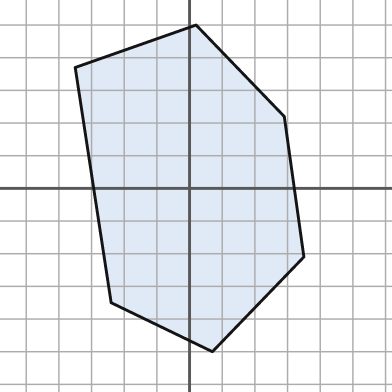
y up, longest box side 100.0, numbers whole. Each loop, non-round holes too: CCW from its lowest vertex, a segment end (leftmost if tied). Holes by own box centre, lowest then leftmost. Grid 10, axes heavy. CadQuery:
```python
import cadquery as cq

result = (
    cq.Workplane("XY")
    .moveTo(7.0, -50.0)
    .lineTo(35.0, -21.0)
    .lineTo(29.0, 22.0)
    .lineTo(2.0, 50.0)
    .lineTo(-35.0, 37.0)
    .lineTo(-24.0, -35.0)
    .close()
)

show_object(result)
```